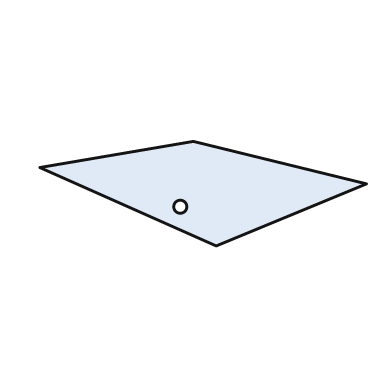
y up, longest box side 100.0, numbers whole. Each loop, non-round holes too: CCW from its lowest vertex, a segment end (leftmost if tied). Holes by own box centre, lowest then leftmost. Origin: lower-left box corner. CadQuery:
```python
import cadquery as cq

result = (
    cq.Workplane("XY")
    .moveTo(54.0, 0.0)
    .lineTo(100.0, 19.0)
    .lineTo(47.0, 32.0)
    .lineTo(0.0, 24.0)
    .close()
    .moveTo(43.0, 12.0)
    .circle(2.0)
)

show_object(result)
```